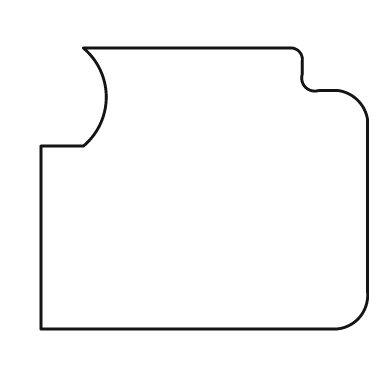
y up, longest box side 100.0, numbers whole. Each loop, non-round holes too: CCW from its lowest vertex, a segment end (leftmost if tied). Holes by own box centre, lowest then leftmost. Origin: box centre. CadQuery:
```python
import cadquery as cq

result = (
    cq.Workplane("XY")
    .moveTo(-50.0, -43.0)
    .lineTo(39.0, -43.0)
    .threePointArc((47.0, -40.0), (50.0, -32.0))
    .lineTo(50.0, 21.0)
    .threePointArc((47.0, 27.0), (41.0, 30.0))
    .lineTo(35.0, 30.0)
    .threePointArc((31.0, 31.0), (30.0, 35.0))
    .lineTo(30.0, 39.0)
    .threePointArc((29.0, 42.0), (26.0, 43.0))
    .lineTo(-37.0, 43.0)
    .threePointArc((-30.0, 28.0), (-37.0, 13.0))
    .lineTo(-50.0, 13.0)
    .close()
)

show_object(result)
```